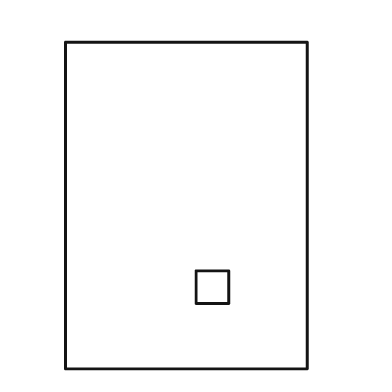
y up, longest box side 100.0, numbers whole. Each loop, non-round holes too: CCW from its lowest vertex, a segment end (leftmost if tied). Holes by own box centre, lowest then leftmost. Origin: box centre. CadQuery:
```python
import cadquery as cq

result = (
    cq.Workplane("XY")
    .moveTo(-37.0, -50.0)
    .lineTo(37.0, -50.0)
    .lineTo(37.0, 50.0)
    .lineTo(-37.0, 50.0)
    .close()
    .moveTo(3.0, -30.0)
    .lineTo(13.0, -30.0)
    .lineTo(13.0, -20.0)
    .lineTo(3.0, -20.0)
    .close()
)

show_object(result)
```